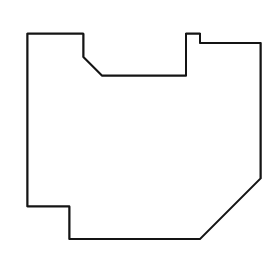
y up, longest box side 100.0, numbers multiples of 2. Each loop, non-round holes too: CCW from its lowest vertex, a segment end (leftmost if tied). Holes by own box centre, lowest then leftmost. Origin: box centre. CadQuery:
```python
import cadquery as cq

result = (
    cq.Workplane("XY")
    .moveTo(-32.0, -44.0)
    .lineTo(24.0, -44.0)
    .lineTo(50.0, -18.0)
    .lineTo(50.0, 40.0)
    .lineTo(24.0, 40.0)
    .lineTo(24.0, 44.0)
    .lineTo(18.0, 44.0)
    .lineTo(18.0, 26.0)
    .lineTo(-18.0, 26.0)
    .lineTo(-26.0, 34.0)
    .lineTo(-26.0, 44.0)
    .lineTo(-50.0, 44.0)
    .lineTo(-50.0, -30.0)
    .lineTo(-32.0, -30.0)
    .close()
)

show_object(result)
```